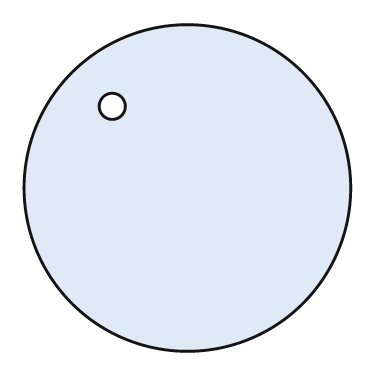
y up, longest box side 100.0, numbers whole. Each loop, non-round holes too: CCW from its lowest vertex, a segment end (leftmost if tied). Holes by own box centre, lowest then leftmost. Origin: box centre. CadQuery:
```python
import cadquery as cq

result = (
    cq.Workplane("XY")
    .moveTo(0.0, 0.0)
    .circle(50.0)
    .moveTo(-23.0, 25.0)
    .circle(4.0)
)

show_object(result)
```